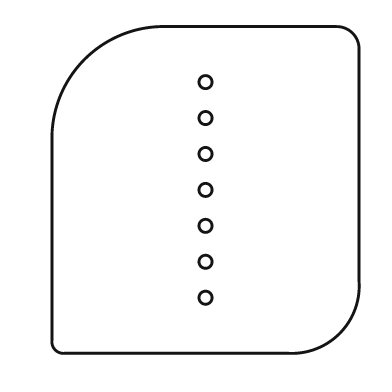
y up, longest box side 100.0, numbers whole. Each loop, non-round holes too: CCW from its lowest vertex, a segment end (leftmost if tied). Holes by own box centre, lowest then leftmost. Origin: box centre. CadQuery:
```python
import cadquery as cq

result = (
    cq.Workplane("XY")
    .moveTo(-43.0, -50.0)
    .lineTo(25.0, -50.0)
    .threePointArc((41.0, -44.0), (47.0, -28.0))
    .lineTo(47.0, 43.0)
    .threePointArc((45.0, 48.0), (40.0, 50.0))
    .lineTo(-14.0, 50.0)
    .threePointArc((-37.0, 40.0), (-47.0, 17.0))
    .lineTo(-47.0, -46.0)
    .threePointArc((-46.0, -49.0), (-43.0, -50.0))
    .close()
    .moveTo(0.0, -33.0)
    .circle(2.0)
    .moveTo(0.0, -22.0)
    .circle(2.0)
    .moveTo(0.0, -11.0)
    .circle(2.0)
    .moveTo(0.0, 0.0)
    .circle(2.0)
    .moveTo(0.0, 11.0)
    .circle(2.0)
    .moveTo(0.0, 22.0)
    .circle(2.0)
    .moveTo(0.0, 33.0)
    .circle(2.0)
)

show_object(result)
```